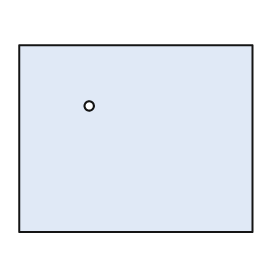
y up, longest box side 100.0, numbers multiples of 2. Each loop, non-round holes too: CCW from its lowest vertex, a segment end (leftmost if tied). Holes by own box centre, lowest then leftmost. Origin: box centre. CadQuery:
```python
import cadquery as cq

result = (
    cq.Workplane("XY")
    .moveTo(-50.0, -40.0)
    .lineTo(50.0, -40.0)
    .lineTo(50.0, 40.0)
    .lineTo(-50.0, 40.0)
    .close()
    .moveTo(-20.0, 14.0)
    .circle(2.0)
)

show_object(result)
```